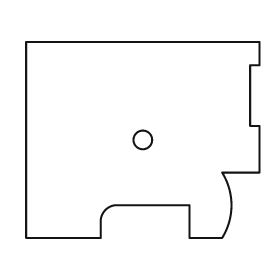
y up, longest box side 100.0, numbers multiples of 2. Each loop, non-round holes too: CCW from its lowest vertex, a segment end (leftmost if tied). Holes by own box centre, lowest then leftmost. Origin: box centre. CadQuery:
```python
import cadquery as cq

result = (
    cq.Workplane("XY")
    .moveTo(-50.0, -42.0)
    .lineTo(-18.0, -42.0)
    .lineTo(-18.0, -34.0)
    .threePointArc((-16.0, -30.0), (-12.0, -28.0))
    .lineTo(20.0, -28.0)
    .lineTo(20.0, -42.0)
    .lineTo(34.0, -42.0)
    .threePointArc((38.0, -28.0), (34.0, -14.0))
    .lineTo(50.0, -14.0)
    .lineTo(50.0, 6.0)
    .lineTo(46.0, 6.0)
    .lineTo(46.0, 32.0)
    .lineTo(50.0, 32.0)
    .lineTo(50.0, 42.0)
    .lineTo(-50.0, 42.0)
    .close()
    .moveTo(0.0, 0.0)
    .circle(4.0)
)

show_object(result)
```